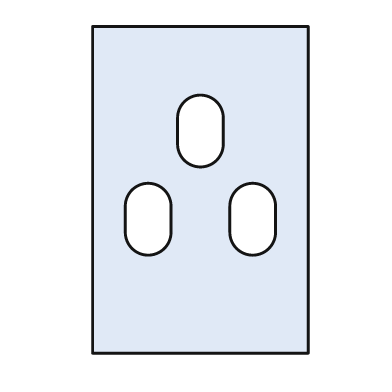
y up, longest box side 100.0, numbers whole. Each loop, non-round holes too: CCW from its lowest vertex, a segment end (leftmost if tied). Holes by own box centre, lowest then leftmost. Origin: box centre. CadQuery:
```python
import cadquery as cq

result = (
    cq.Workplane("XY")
    .moveTo(-33.0, -50.0)
    .lineTo(33.0, -50.0)
    .lineTo(33.0, 50.0)
    .lineTo(-33.0, 50.0)
    .close()
    .moveTo(-23.0, -13.0)
    .threePointArc((-16.0, -20.0), (-9.0, -13.0))
    .lineTo(-9.0, -5.0)
    .threePointArc((-16.0, 2.0), (-23.0, -5.0))
    .close()
    .moveTo(9.0, -13.0)
    .threePointArc((16.0, -20.0), (23.0, -13.0))
    .lineTo(23.0, -5.0)
    .threePointArc((16.0, 2.0), (9.0, -5.0))
    .close()
    .moveTo(-7.0, 14.0)
    .threePointArc((0.0, 7.0), (7.0, 14.0))
    .lineTo(7.0, 22.0)
    .threePointArc((0.0, 29.0), (-7.0, 22.0))
    .close()
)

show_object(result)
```